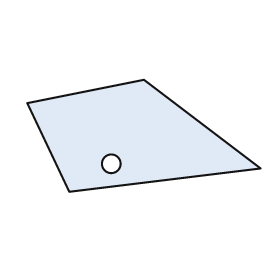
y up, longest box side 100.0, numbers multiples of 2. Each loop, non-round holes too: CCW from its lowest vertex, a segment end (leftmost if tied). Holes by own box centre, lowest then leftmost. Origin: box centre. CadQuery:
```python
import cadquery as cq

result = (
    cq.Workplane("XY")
    .moveTo(-32.0, -24.0)
    .lineTo(50.0, -14.0)
    .lineTo(0.0, 24.0)
    .lineTo(-50.0, 14.0)
    .close()
    .moveTo(-14.0, -12.0)
    .circle(4.0)
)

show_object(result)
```